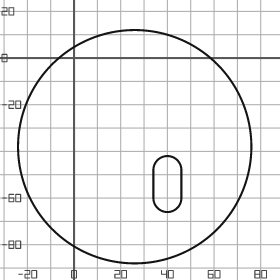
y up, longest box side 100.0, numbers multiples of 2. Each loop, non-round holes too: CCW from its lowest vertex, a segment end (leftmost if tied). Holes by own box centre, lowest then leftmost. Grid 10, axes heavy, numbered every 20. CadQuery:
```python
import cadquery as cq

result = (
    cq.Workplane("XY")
    .moveTo(26.0, -38.0)
    .circle(50.0)
    .moveTo(34.0, -60.0)
    .threePointArc((40.0, -66.0), (46.0, -60.0))
    .lineTo(46.0, -48.0)
    .threePointArc((40.0, -42.0), (34.0, -48.0))
    .close()
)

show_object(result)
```